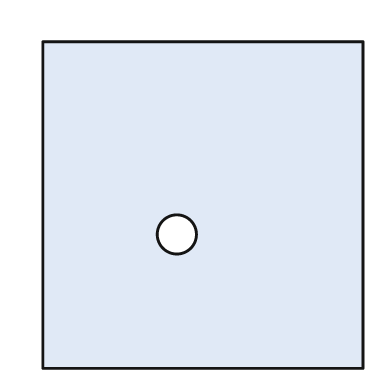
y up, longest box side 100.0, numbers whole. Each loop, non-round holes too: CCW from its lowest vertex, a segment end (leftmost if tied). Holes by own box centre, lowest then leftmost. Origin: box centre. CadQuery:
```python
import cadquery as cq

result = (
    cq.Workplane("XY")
    .moveTo(-49.0, -50.0)
    .lineTo(49.0, -50.0)
    .lineTo(49.0, 50.0)
    .lineTo(-49.0, 50.0)
    .close()
    .moveTo(-8.0, -9.0)
    .circle(6.0)
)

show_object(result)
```